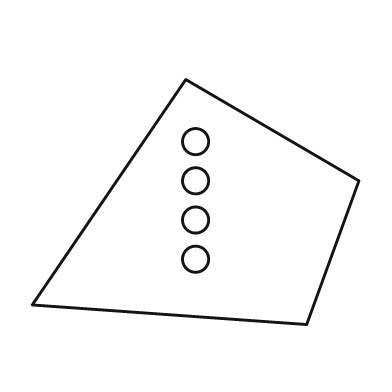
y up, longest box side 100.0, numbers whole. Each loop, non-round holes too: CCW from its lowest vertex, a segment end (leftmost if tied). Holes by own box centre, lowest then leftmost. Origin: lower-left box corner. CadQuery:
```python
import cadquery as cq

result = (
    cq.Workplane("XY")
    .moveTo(84.0, 0.0)
    .lineTo(100.0, 44.0)
    .lineTo(47.0, 75.0)
    .lineTo(0.0, 6.0)
    .close()
    .moveTo(50.0, 20.0)
    .circle(4.0)
    .moveTo(50.0, 32.0)
    .circle(4.0)
    .moveTo(50.0, 44.0)
    .circle(4.0)
    .moveTo(50.0, 56.0)
    .circle(4.0)
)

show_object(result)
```